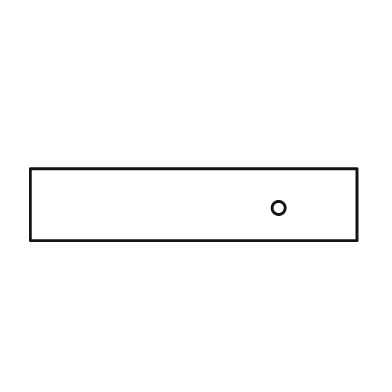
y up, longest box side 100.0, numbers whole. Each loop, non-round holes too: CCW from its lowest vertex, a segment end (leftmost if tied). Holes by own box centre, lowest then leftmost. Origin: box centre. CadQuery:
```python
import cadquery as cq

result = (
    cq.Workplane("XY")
    .moveTo(-50.0, -11.0)
    .lineTo(50.0, -11.0)
    .lineTo(50.0, 11.0)
    .lineTo(-50.0, 11.0)
    .close()
    .moveTo(26.0, -1.0)
    .circle(2.0)
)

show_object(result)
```